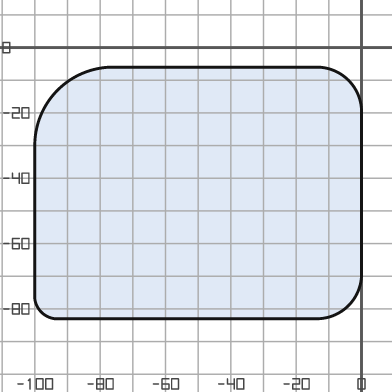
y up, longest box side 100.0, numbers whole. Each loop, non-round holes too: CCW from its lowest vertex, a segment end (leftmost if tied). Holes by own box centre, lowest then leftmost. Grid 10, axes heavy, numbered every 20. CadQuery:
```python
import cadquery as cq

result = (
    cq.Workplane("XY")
    .moveTo(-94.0, -83.0)
    .lineTo(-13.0, -83.0)
    .threePointArc((-4.0, -79.0), (0.0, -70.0))
    .lineTo(0.0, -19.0)
    .threePointArc((-4.0, -10.0), (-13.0, -6.0))
    .lineTo(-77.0, -6.0)
    .threePointArc((-93.0, -13.0), (-100.0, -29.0))
    .lineTo(-100.0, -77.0)
    .threePointArc((-98.0, -81.0), (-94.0, -83.0))
    .close()
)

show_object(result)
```